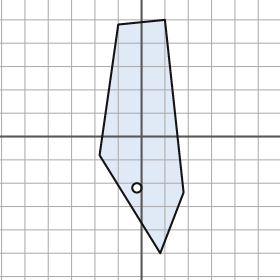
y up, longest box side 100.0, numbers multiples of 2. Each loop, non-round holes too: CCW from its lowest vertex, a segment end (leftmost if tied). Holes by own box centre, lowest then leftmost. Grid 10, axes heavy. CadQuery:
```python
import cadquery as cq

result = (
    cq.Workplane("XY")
    .moveTo(8.0, -50.0)
    .lineTo(18.0, -24.0)
    .lineTo(10.0, 50.0)
    .lineTo(-10.0, 48.0)
    .lineTo(-18.0, -8.0)
    .close()
    .moveTo(-2.0, -22.0)
    .circle(2.0)
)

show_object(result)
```